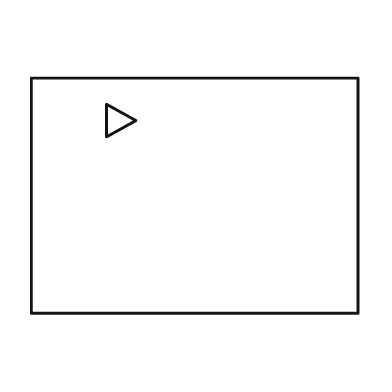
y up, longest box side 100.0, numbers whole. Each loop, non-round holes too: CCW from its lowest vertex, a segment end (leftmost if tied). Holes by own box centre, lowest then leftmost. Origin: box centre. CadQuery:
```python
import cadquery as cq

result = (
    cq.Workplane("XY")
    .moveTo(-50.0, -36.0)
    .lineTo(50.0, -36.0)
    .lineTo(50.0, 36.0)
    .lineTo(-50.0, 36.0)
    .close()
    .moveTo(-27.0, 18.0)
    .lineTo(-18.0, 23.0)
    .lineTo(-27.0, 28.0)
    .close()
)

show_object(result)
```